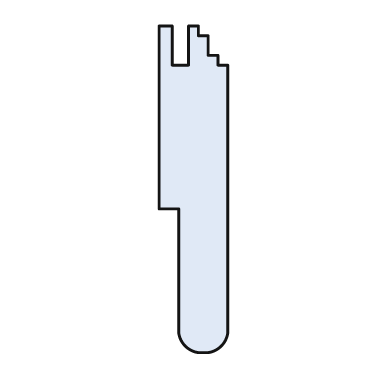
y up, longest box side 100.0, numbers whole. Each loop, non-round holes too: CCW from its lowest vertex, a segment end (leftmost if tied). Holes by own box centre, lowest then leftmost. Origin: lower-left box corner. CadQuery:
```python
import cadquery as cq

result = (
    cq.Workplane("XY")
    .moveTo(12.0, 0.0)
    .lineTo(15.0, 0.0)
    .threePointArc((19.0, 2.0), (21.0, 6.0))
    .lineTo(21.0, 88.0)
    .lineTo(18.0, 88.0)
    .lineTo(18.0, 91.0)
    .lineTo(15.0, 91.0)
    .lineTo(15.0, 97.0)
    .lineTo(12.0, 97.0)
    .lineTo(12.0, 100.0)
    .lineTo(9.0, 100.0)
    .lineTo(9.0, 88.0)
    .lineTo(4.0, 88.0)
    .lineTo(4.0, 100.0)
    .lineTo(0.0, 100.0)
    .lineTo(0.0, 44.0)
    .lineTo(6.0, 44.0)
    .lineTo(6.0, 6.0)
    .threePointArc((8.0, 2.0), (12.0, 0.0))
    .close()
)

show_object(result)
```